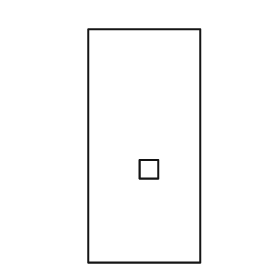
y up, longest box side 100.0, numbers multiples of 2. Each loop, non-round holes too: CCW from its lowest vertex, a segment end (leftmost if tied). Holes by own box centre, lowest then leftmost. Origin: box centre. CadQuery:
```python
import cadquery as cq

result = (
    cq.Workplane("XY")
    .moveTo(-24.0, -50.0)
    .lineTo(24.0, -50.0)
    .lineTo(24.0, 50.0)
    .lineTo(-24.0, 50.0)
    .close()
    .moveTo(-2.0, -14.0)
    .lineTo(6.0, -14.0)
    .lineTo(6.0, -6.0)
    .lineTo(-2.0, -6.0)
    .close()
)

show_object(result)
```